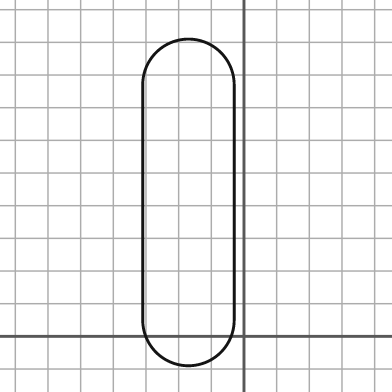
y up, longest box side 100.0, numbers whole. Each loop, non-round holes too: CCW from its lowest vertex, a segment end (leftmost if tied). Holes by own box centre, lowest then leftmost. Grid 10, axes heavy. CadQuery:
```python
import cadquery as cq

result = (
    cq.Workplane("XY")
    .moveTo(-31.0, 5.0)
    .threePointArc((-17.0, -9.0), (-3.0, 5.0))
    .lineTo(-3.0, 77.0)
    .threePointArc((-17.0, 91.0), (-31.0, 77.0))
    .close()
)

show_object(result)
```